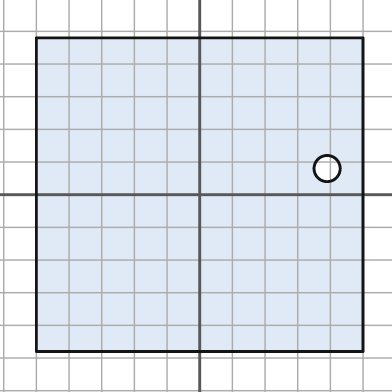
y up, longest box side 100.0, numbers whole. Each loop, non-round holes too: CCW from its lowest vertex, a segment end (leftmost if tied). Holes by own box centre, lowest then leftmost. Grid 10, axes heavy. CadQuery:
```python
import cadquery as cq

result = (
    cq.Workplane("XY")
    .moveTo(-50.0, -48.0)
    .lineTo(50.0, -48.0)
    .lineTo(50.0, 48.0)
    .lineTo(-50.0, 48.0)
    .close()
    .moveTo(39.0, 8.0)
    .circle(4.0)
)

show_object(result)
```